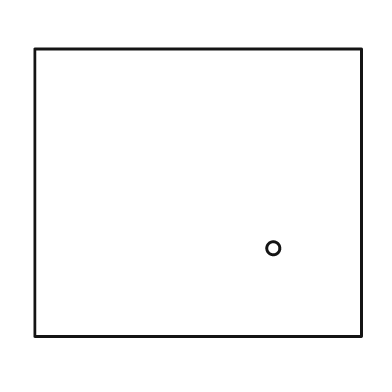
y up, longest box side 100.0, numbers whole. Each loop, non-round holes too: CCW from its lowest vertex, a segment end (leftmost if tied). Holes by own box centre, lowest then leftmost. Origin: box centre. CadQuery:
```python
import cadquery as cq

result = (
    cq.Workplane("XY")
    .moveTo(-50.0, -44.0)
    .lineTo(50.0, -44.0)
    .lineTo(50.0, 44.0)
    .lineTo(-50.0, 44.0)
    .close()
    .moveTo(23.0, -17.0)
    .circle(2.0)
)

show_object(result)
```